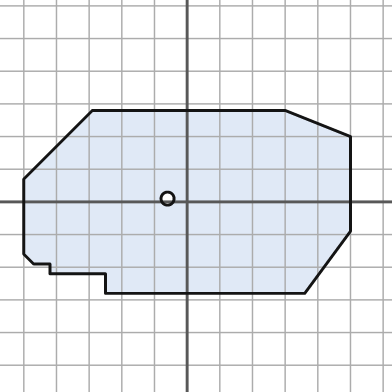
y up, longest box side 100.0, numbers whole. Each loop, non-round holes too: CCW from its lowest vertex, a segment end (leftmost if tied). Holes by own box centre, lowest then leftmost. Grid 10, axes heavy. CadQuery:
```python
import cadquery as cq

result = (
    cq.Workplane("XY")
    .moveTo(-25.0, -28.0)
    .lineTo(36.0, -28.0)
    .lineTo(50.0, -9.0)
    .lineTo(50.0, 20.0)
    .lineTo(30.0, 28.0)
    .lineTo(-29.0, 28.0)
    .lineTo(-50.0, 7.0)
    .lineTo(-50.0, -16.0)
    .lineTo(-47.0, -19.0)
    .lineTo(-42.0, -19.0)
    .lineTo(-42.0, -22.0)
    .lineTo(-25.0, -22.0)
    .close()
    .moveTo(-6.0, 1.0)
    .circle(2.0)
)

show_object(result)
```